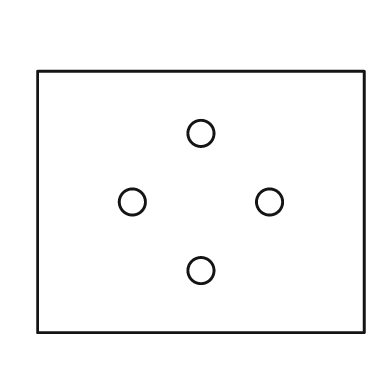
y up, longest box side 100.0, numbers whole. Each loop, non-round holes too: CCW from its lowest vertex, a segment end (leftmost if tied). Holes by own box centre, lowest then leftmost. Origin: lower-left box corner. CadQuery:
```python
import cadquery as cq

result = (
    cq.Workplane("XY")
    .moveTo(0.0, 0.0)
    .lineTo(100.0, 0.0)
    .lineTo(100.0, 80.0)
    .lineTo(0.0, 80.0)
    .close()
    .moveTo(50.0, 19.0)
    .circle(4.0)
    .moveTo(29.0, 40.0)
    .circle(4.0)
    .moveTo(71.0, 40.0)
    .circle(4.0)
    .moveTo(50.0, 61.0)
    .circle(4.0)
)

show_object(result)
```